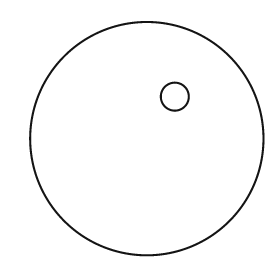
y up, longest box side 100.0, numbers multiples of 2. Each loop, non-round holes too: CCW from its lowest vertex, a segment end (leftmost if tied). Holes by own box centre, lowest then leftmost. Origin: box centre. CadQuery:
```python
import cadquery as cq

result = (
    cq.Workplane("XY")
    .moveTo(0.0, 0.0)
    .circle(50.0)
    .moveTo(12.0, 18.0)
    .circle(6.0)
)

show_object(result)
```